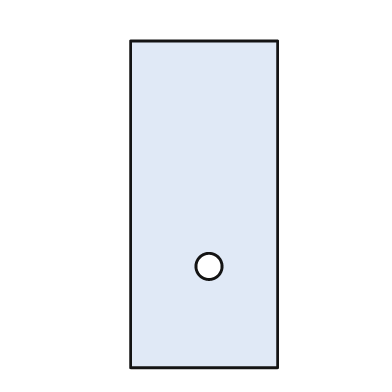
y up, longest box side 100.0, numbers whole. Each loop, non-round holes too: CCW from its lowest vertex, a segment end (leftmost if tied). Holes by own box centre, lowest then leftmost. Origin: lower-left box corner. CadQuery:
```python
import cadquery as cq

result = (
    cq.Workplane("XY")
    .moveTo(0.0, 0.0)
    .lineTo(45.0, 0.0)
    .lineTo(45.0, 100.0)
    .lineTo(0.0, 100.0)
    .close()
    .moveTo(24.0, 31.0)
    .circle(4.0)
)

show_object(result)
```